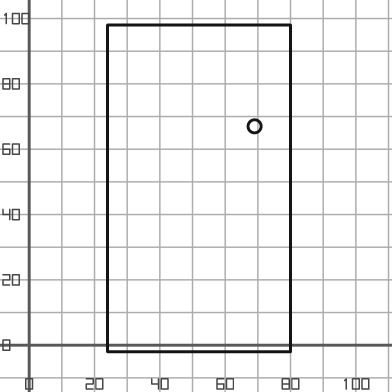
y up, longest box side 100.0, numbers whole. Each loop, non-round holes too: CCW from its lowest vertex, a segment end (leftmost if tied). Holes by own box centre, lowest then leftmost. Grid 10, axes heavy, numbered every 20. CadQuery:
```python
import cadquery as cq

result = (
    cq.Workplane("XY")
    .moveTo(24.0, -2.0)
    .lineTo(80.0, -2.0)
    .lineTo(80.0, 98.0)
    .lineTo(24.0, 98.0)
    .close()
    .moveTo(69.0, 67.0)
    .circle(2.0)
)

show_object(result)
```